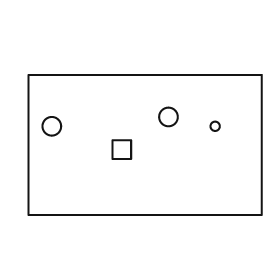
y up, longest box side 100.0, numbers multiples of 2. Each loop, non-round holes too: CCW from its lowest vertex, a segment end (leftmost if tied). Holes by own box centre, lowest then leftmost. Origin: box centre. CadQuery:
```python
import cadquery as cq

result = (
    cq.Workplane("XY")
    .moveTo(-50.0, -30.0)
    .lineTo(50.0, -30.0)
    .lineTo(50.0, 30.0)
    .lineTo(-50.0, 30.0)
    .close()
    .moveTo(-14.0, -6.0)
    .lineTo(-6.0, -6.0)
    .lineTo(-6.0, 2.0)
    .lineTo(-14.0, 2.0)
    .close()
    .moveTo(-40.0, 8.0)
    .circle(4.0)
    .moveTo(30.0, 8.0)
    .circle(2.0)
    .moveTo(10.0, 12.0)
    .circle(4.0)
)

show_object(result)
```